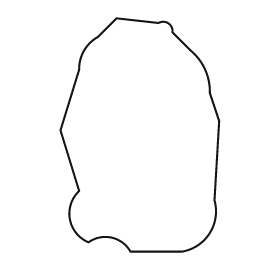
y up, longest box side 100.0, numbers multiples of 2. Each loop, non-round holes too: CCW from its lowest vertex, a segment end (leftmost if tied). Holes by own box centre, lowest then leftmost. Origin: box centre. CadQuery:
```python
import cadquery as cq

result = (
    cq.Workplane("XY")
    .moveTo(-4.0, -50.0)
    .lineTo(18.0, -50.0)
    .threePointArc((30.0, -42.0), (32.0, -28.0))
    .lineTo(34.0, 6.0)
    .lineTo(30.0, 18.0)
    .threePointArc((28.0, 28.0), (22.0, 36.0))
    .lineTo(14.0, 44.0)
    .threePointArc((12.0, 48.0), (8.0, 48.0))
    .lineTo(-10.0, 50.0)
    .lineTo(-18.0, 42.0)
    .threePointArc((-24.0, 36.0), (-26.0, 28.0))
    .lineTo(-34.0, 2.0)
    .lineTo(-26.0, -24.0)
    .threePointArc((-30.0, -36.0), (-22.0, -46.0))
    .threePointArc((-12.0, -44.0), (-4.0, -50.0))
    .close()
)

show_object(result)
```